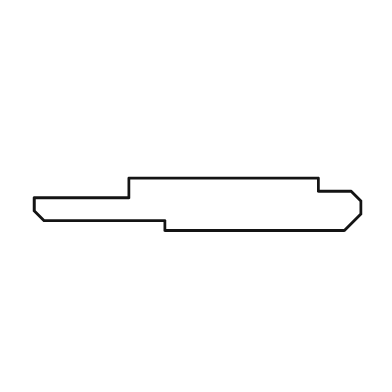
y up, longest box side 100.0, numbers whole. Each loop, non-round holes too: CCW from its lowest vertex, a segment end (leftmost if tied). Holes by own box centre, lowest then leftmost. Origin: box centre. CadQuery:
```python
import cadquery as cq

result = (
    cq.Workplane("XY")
    .moveTo(-10.0, -8.0)
    .lineTo(45.0, -8.0)
    .lineTo(50.0, -3.0)
    .lineTo(50.0, 1.0)
    .lineTo(47.0, 4.0)
    .lineTo(37.0, 4.0)
    .lineTo(37.0, 8.0)
    .lineTo(-21.0, 8.0)
    .lineTo(-21.0, 2.0)
    .lineTo(-50.0, 2.0)
    .lineTo(-50.0, -2.0)
    .lineTo(-47.0, -5.0)
    .lineTo(-10.0, -5.0)
    .close()
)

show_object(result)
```